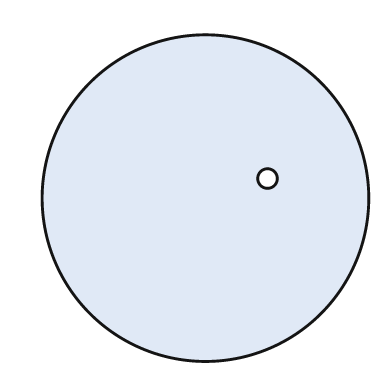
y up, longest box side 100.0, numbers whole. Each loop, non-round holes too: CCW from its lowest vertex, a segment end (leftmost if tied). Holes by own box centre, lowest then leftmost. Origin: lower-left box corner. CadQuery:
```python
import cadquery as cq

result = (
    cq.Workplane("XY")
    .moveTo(50.0, 50.0)
    .circle(50.0)
    .moveTo(69.0, 56.0)
    .circle(3.0)
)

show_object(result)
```